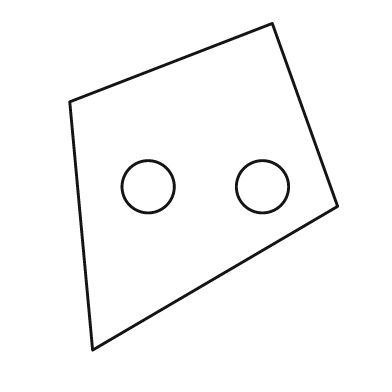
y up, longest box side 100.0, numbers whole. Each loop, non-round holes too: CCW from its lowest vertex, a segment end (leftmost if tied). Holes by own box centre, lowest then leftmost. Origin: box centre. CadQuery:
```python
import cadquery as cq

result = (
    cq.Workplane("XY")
    .moveTo(-34.0, -50.0)
    .lineTo(41.0, -6.0)
    .lineTo(21.0, 50.0)
    .lineTo(-41.0, 26.0)
    .close()
    .moveTo(-17.0, 0.0)
    .circle(8.0)
    .moveTo(18.0, 0.0)
    .circle(8.0)
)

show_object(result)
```